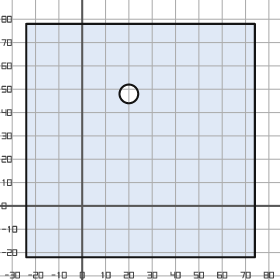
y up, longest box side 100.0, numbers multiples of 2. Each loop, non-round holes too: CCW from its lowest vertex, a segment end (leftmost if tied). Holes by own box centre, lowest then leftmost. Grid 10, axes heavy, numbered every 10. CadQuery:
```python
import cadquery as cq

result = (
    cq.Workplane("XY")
    .moveTo(-24.0, -22.0)
    .lineTo(74.0, -22.0)
    .lineTo(74.0, 78.0)
    .lineTo(-24.0, 78.0)
    .close()
    .moveTo(20.0, 48.0)
    .circle(4.0)
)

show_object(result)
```